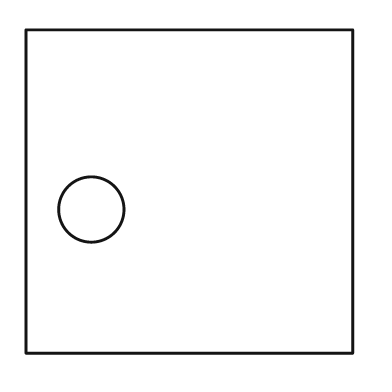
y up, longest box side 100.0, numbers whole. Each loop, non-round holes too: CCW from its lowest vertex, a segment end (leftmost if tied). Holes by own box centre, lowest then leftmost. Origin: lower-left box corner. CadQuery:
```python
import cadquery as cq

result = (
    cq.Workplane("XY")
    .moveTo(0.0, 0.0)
    .lineTo(100.0, 0.0)
    .lineTo(100.0, 99.0)
    .lineTo(0.0, 99.0)
    .close()
    .moveTo(20.0, 44.0)
    .circle(10.0)
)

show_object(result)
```